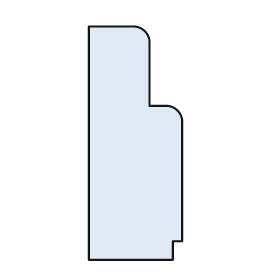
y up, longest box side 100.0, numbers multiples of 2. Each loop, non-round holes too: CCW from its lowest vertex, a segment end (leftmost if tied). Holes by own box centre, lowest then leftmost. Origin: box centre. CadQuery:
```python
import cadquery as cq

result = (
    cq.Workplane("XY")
    .moveTo(-20.0, -50.0)
    .lineTo(16.0, -50.0)
    .lineTo(16.0, -42.0)
    .lineTo(20.0, -42.0)
    .lineTo(20.0, 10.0)
    .threePointArc((18.0, 14.0), (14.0, 16.0))
    .lineTo(6.0, 16.0)
    .lineTo(6.0, 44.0)
    .threePointArc((4.0, 48.0), (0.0, 50.0))
    .lineTo(-20.0, 50.0)
    .close()
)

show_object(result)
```